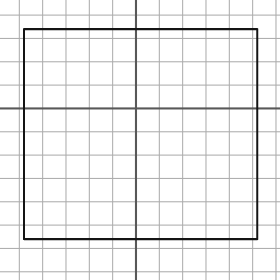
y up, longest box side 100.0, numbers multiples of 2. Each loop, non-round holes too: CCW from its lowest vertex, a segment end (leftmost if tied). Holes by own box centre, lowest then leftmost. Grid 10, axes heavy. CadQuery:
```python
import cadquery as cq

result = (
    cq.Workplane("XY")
    .moveTo(-48.0, -56.0)
    .lineTo(52.0, -56.0)
    .lineTo(52.0, 34.0)
    .lineTo(-48.0, 34.0)
    .close()
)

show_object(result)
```